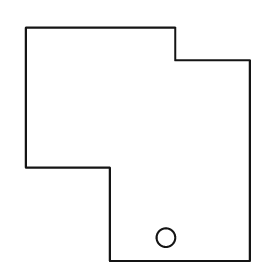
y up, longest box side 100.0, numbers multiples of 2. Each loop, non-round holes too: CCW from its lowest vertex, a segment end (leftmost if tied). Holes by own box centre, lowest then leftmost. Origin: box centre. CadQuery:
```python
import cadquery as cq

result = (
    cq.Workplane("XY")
    .moveTo(-12.0, -50.0)
    .lineTo(48.0, -50.0)
    .lineTo(48.0, 36.0)
    .lineTo(16.0, 36.0)
    .lineTo(16.0, 50.0)
    .lineTo(-48.0, 50.0)
    .lineTo(-48.0, -10.0)
    .lineTo(-12.0, -10.0)
    .close()
    .moveTo(12.0, -40.0)
    .circle(4.0)
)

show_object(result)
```